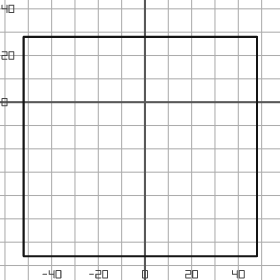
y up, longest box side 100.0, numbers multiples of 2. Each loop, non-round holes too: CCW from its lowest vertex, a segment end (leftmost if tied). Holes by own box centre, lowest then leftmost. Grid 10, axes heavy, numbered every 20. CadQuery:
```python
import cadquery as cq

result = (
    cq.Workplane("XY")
    .moveTo(-52.0, -66.0)
    .lineTo(48.0, -66.0)
    .lineTo(48.0, 28.0)
    .lineTo(-52.0, 28.0)
    .close()
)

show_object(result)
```